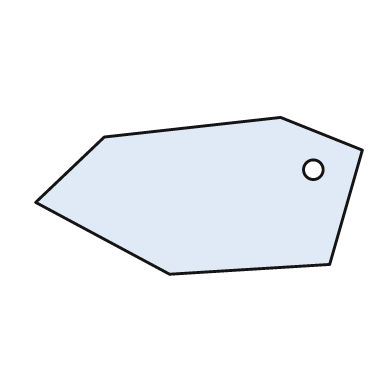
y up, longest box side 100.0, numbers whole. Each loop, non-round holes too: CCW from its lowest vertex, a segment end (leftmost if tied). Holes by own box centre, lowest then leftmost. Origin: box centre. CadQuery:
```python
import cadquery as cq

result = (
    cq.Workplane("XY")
    .moveTo(-9.0, -24.0)
    .lineTo(40.0, -21.0)
    .lineTo(50.0, 14.0)
    .lineTo(25.0, 24.0)
    .lineTo(-29.0, 18.0)
    .lineTo(-50.0, -2.0)
    .close()
    .moveTo(35.0, 8.0)
    .circle(3.0)
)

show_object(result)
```